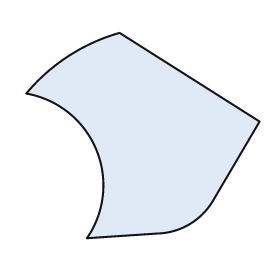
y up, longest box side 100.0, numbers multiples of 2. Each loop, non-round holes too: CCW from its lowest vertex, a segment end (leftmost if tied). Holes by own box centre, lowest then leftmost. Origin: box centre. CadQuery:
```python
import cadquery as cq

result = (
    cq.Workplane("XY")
    .moveTo(-24.0, -44.0)
    .lineTo(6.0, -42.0)
    .threePointArc((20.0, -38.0), (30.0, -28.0))
    .lineTo(50.0, 6.0)
    .lineTo(-10.0, 44.0)
    .threePointArc((-32.0, 34.0), (-50.0, 18.0))
    .threePointArc((-20.0, -6.0), (-24.0, -44.0))
    .close()
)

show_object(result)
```